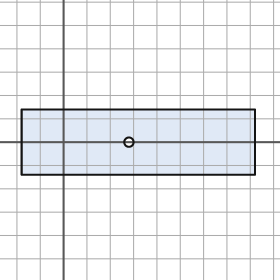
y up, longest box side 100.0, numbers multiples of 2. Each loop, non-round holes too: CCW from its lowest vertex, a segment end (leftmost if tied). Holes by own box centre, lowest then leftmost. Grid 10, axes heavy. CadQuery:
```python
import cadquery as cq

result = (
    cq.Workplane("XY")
    .moveTo(-18.0, -14.0)
    .lineTo(82.0, -14.0)
    .lineTo(82.0, 14.0)
    .lineTo(-18.0, 14.0)
    .close()
    .moveTo(28.0, 0.0)
    .circle(2.0)
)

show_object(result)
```